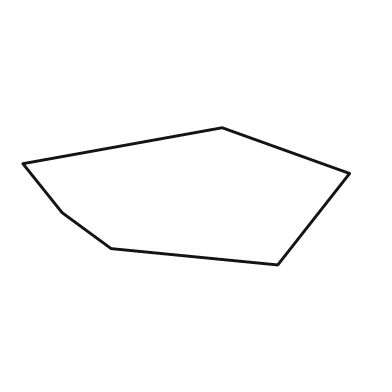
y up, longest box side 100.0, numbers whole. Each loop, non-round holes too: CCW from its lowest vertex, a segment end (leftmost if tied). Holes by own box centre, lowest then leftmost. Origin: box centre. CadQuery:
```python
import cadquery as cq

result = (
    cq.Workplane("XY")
    .moveTo(28.0, -21.0)
    .lineTo(50.0, 7.0)
    .lineTo(11.0, 21.0)
    .lineTo(-50.0, 10.0)
    .lineTo(-38.0, -5.0)
    .lineTo(-23.0, -16.0)
    .close()
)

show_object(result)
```